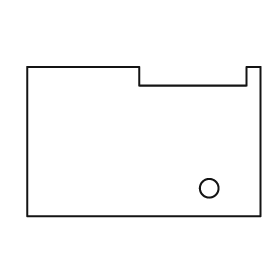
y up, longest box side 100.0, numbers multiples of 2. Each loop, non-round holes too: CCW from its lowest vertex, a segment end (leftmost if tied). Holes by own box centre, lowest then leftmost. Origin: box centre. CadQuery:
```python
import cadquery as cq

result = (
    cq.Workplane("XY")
    .moveTo(-50.0, -32.0)
    .lineTo(50.0, -32.0)
    .lineTo(50.0, 32.0)
    .lineTo(44.0, 32.0)
    .lineTo(44.0, 24.0)
    .lineTo(-2.0, 24.0)
    .lineTo(-2.0, 32.0)
    .lineTo(-50.0, 32.0)
    .close()
    .moveTo(28.0, -20.0)
    .circle(4.0)
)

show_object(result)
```